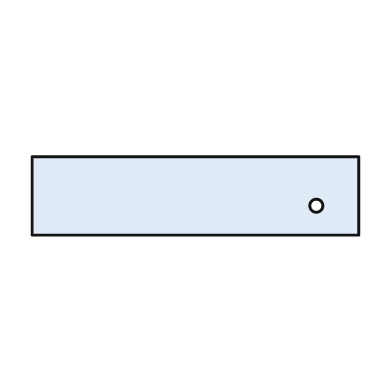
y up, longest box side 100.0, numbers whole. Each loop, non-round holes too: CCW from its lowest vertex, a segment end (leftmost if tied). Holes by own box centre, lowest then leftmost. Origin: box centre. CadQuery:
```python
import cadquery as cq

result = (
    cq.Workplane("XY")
    .moveTo(-50.0, -12.0)
    .lineTo(50.0, -12.0)
    .lineTo(50.0, 12.0)
    .lineTo(-50.0, 12.0)
    .close()
    .moveTo(37.0, -3.0)
    .circle(2.0)
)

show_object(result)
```